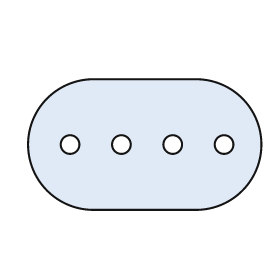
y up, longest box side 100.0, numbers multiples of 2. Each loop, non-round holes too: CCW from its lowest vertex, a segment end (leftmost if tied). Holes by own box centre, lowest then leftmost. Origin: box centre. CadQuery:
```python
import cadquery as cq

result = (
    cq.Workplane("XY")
    .moveTo(-22.0, -28.0)
    .lineTo(22.0, -28.0)
    .threePointArc((50.0, 0.0), (22.0, 28.0))
    .lineTo(-22.0, 28.0)
    .threePointArc((-50.0, 0.0), (-22.0, -28.0))
    .close()
    .moveTo(-32.0, 0.0)
    .circle(4.0)
    .moveTo(-10.0, 0.0)
    .circle(4.0)
    .moveTo(12.0, 0.0)
    .circle(4.0)
    .moveTo(34.0, 0.0)
    .circle(4.0)
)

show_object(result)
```